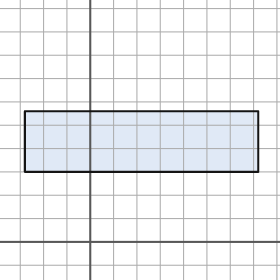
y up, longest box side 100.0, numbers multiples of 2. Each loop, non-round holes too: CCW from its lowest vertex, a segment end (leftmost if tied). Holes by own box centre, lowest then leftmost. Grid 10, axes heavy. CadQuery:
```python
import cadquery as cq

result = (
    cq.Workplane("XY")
    .moveTo(-28.0, 30.0)
    .lineTo(72.0, 30.0)
    .lineTo(72.0, 56.0)
    .lineTo(-28.0, 56.0)
    .close()
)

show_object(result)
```